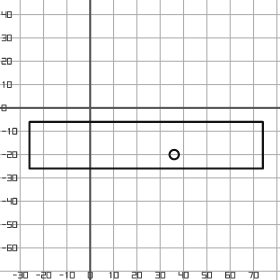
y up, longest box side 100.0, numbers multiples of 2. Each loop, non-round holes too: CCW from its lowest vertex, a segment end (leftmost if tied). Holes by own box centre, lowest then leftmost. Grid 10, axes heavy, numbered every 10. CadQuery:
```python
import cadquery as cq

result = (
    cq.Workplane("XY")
    .moveTo(-26.0, -26.0)
    .lineTo(74.0, -26.0)
    .lineTo(74.0, -6.0)
    .lineTo(-26.0, -6.0)
    .close()
    .moveTo(36.0, -20.0)
    .circle(2.0)
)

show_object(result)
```